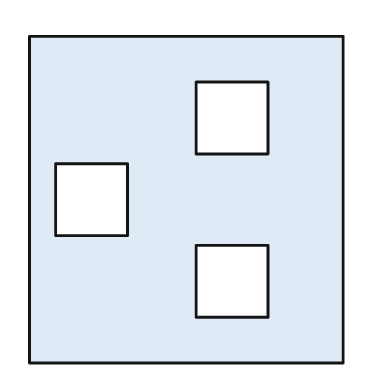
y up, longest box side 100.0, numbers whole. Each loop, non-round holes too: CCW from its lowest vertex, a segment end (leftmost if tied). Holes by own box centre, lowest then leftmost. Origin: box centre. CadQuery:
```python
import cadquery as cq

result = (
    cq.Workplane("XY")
    .moveTo(-48.0, -50.0)
    .lineTo(48.0, -50.0)
    .lineTo(48.0, 50.0)
    .lineTo(-48.0, 50.0)
    .close()
    .moveTo(3.0, -36.0)
    .lineTo(25.0, -36.0)
    .lineTo(25.0, -14.0)
    .lineTo(3.0, -14.0)
    .close()
    .moveTo(-40.0, -11.0)
    .lineTo(-18.0, -11.0)
    .lineTo(-18.0, 11.0)
    .lineTo(-40.0, 11.0)
    .close()
    .moveTo(3.0, 14.0)
    .lineTo(25.0, 14.0)
    .lineTo(25.0, 36.0)
    .lineTo(3.0, 36.0)
    .close()
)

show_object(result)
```